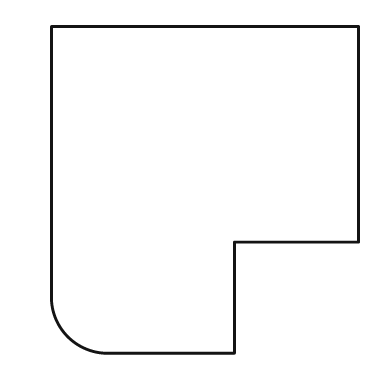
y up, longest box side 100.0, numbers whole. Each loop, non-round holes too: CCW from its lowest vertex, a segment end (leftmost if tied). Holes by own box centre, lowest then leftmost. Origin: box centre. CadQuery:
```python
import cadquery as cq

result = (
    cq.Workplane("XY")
    .moveTo(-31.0, -50.0)
    .lineTo(9.0, -50.0)
    .lineTo(9.0, -16.0)
    .lineTo(47.0, -16.0)
    .lineTo(47.0, 50.0)
    .lineTo(-47.0, 50.0)
    .lineTo(-47.0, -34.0)
    .threePointArc((-42.0, -45.0), (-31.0, -50.0))
    .close()
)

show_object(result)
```